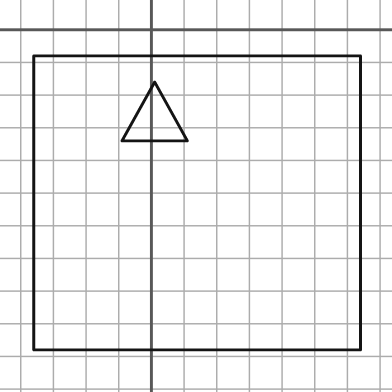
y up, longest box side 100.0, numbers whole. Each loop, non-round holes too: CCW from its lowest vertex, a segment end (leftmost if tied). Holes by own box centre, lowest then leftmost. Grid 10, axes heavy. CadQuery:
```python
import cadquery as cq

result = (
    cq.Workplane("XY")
    .moveTo(-36.0, -98.0)
    .lineTo(64.0, -98.0)
    .lineTo(64.0, -8.0)
    .lineTo(-36.0, -8.0)
    .close()
    .moveTo(-9.0, -34.0)
    .lineTo(11.0, -34.0)
    .lineTo(1.0, -16.0)
    .close()
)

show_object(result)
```